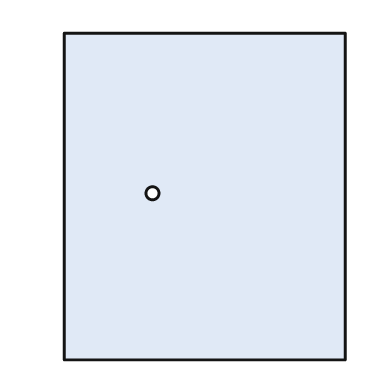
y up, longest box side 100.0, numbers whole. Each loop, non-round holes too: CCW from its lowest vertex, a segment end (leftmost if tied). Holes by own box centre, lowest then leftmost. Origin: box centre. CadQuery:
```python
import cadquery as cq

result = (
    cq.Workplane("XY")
    .moveTo(-43.0, -50.0)
    .lineTo(43.0, -50.0)
    .lineTo(43.0, 50.0)
    .lineTo(-43.0, 50.0)
    .close()
    .moveTo(-16.0, 1.0)
    .circle(2.0)
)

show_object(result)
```